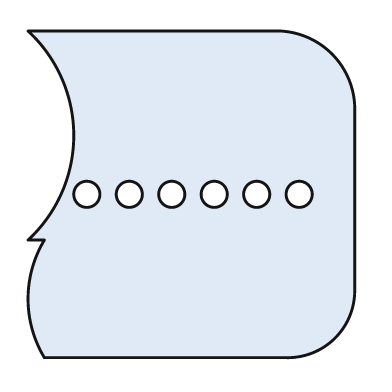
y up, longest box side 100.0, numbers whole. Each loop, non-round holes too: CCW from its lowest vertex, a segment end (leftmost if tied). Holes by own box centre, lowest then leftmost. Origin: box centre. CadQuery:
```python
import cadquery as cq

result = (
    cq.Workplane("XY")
    .moveTo(-45.0, -50.0)
    .lineTo(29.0, -50.0)
    .threePointArc((44.0, -44.0), (50.0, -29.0))
    .lineTo(50.0, 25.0)
    .threePointArc((43.0, 43.0), (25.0, 50.0))
    .lineTo(-50.0, 50.0)
    .threePointArc((-36.0, 18.0), (-50.0, -14.0))
    .lineTo(-45.0, -14.0)
    .threePointArc((-50.0, -32.0), (-45.0, -50.0))
    .close()
    .moveTo(-32.0, 0.0)
    .circle(4.0)
    .moveTo(-19.0, 0.0)
    .circle(4.0)
    .moveTo(-6.0, 0.0)
    .circle(4.0)
    .moveTo(7.0, 0.0)
    .circle(4.0)
    .moveTo(20.0, 0.0)
    .circle(4.0)
    .moveTo(33.0, 0.0)
    .circle(4.0)
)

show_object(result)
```